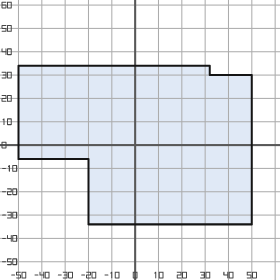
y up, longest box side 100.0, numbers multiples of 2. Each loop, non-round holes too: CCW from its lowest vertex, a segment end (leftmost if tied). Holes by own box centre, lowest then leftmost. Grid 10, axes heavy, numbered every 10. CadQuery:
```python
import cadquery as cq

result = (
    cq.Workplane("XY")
    .moveTo(-20.0, -34.0)
    .lineTo(50.0, -34.0)
    .lineTo(50.0, 30.0)
    .lineTo(32.0, 30.0)
    .lineTo(32.0, 34.0)
    .lineTo(-50.0, 34.0)
    .lineTo(-50.0, -6.0)
    .lineTo(-20.0, -6.0)
    .close()
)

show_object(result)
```